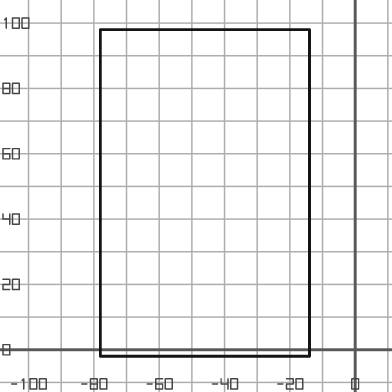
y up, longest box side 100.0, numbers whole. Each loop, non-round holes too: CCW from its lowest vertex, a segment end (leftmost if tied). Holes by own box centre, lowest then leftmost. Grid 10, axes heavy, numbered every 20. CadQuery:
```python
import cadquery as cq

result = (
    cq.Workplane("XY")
    .moveTo(-78.0, -2.0)
    .lineTo(-14.0, -2.0)
    .lineTo(-14.0, 98.0)
    .lineTo(-78.0, 98.0)
    .close()
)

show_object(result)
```